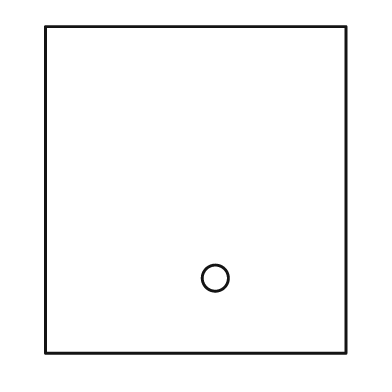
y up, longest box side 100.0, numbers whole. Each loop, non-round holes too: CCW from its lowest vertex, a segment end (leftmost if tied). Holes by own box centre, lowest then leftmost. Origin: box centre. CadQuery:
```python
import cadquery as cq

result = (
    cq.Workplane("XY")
    .moveTo(-46.0, -50.0)
    .lineTo(46.0, -50.0)
    .lineTo(46.0, 50.0)
    .lineTo(-46.0, 50.0)
    .close()
    .moveTo(6.0, -27.0)
    .circle(4.0)
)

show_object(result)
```